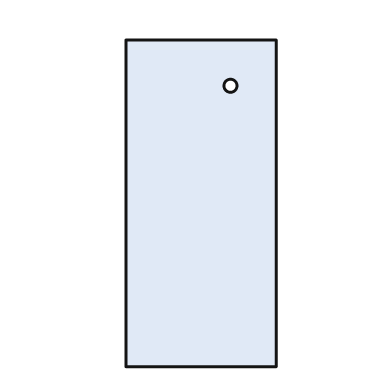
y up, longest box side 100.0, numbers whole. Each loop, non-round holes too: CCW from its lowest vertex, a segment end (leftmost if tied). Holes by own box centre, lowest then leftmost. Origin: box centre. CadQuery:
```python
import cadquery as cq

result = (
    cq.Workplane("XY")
    .moveTo(-23.0, -50.0)
    .lineTo(23.0, -50.0)
    .lineTo(23.0, 50.0)
    .lineTo(-23.0, 50.0)
    .close()
    .moveTo(9.0, 36.0)
    .circle(2.0)
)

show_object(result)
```